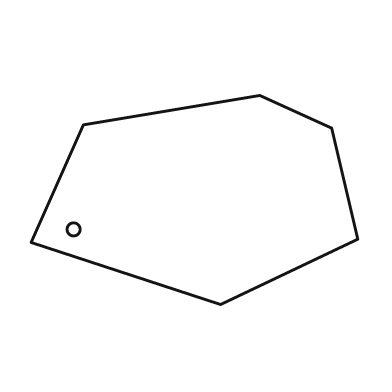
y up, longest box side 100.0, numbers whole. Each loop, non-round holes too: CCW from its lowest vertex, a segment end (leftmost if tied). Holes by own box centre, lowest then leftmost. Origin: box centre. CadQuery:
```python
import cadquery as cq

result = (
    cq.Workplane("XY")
    .moveTo(8.0, -32.0)
    .lineTo(50.0, -12.0)
    .lineTo(42.0, 22.0)
    .lineTo(20.0, 32.0)
    .lineTo(-34.0, 23.0)
    .lineTo(-50.0, -13.0)
    .close()
    .moveTo(-37.0, -9.0)
    .circle(2.0)
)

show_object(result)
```